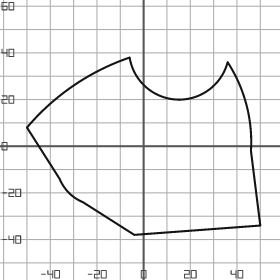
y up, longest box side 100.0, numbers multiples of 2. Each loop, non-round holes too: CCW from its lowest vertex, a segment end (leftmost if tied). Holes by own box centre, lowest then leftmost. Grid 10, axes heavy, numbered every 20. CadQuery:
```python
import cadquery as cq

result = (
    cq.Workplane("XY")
    .moveTo(-4.0, -38.0)
    .lineTo(50.0, -34.0)
    .lineTo(46.0, -2.0)
    .threePointArc((44.0, 18.0), (36.0, 36.0))
    .threePointArc((14.0, 20.0), (-6.0, 38.0))
    .threePointArc((-30.0, 26.0), (-50.0, 8.0))
    .lineTo(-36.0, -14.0)
    .threePointArc((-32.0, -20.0), (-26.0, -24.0))
    .close()
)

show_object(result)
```